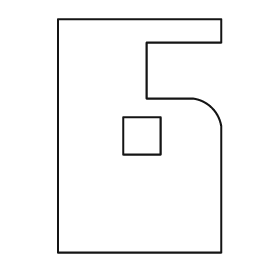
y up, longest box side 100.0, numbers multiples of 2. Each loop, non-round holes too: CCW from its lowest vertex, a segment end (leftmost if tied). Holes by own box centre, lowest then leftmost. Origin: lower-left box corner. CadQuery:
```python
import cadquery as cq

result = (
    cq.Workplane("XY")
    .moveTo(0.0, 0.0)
    .lineTo(70.0, 0.0)
    .lineTo(70.0, 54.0)
    .threePointArc((66.0, 62.0), (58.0, 66.0))
    .lineTo(38.0, 66.0)
    .lineTo(38.0, 90.0)
    .lineTo(70.0, 90.0)
    .lineTo(70.0, 100.0)
    .lineTo(0.0, 100.0)
    .close()
    .moveTo(28.0, 42.0)
    .lineTo(44.0, 42.0)
    .lineTo(44.0, 58.0)
    .lineTo(28.0, 58.0)
    .close()
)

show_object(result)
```